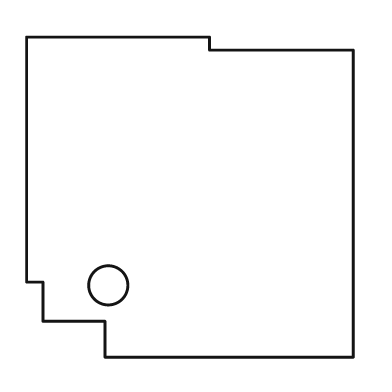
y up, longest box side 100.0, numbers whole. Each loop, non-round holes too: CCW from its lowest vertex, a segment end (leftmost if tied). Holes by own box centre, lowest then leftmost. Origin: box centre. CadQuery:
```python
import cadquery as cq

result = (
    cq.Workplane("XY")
    .moveTo(-26.0, -49.0)
    .lineTo(50.0, -49.0)
    .lineTo(50.0, 45.0)
    .lineTo(6.0, 45.0)
    .lineTo(6.0, 49.0)
    .lineTo(-50.0, 49.0)
    .lineTo(-50.0, -26.0)
    .lineTo(-45.0, -26.0)
    .lineTo(-45.0, -38.0)
    .lineTo(-26.0, -38.0)
    .close()
    .moveTo(-25.0, -27.0)
    .circle(6.0)
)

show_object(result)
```